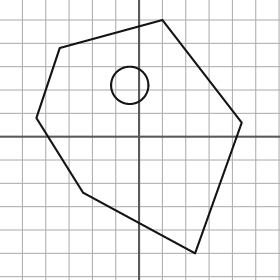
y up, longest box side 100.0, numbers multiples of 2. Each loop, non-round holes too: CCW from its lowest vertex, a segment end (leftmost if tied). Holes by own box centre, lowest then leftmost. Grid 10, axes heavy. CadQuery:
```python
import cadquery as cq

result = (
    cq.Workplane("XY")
    .moveTo(24.0, -50.0)
    .lineTo(44.0, 6.0)
    .lineTo(10.0, 50.0)
    .lineTo(-34.0, 38.0)
    .lineTo(-44.0, 8.0)
    .lineTo(-24.0, -24.0)
    .close()
    .moveTo(-4.0, 22.0)
    .circle(8.0)
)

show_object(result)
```